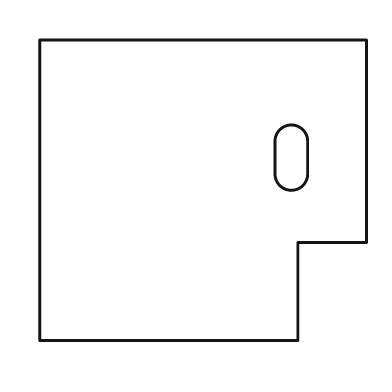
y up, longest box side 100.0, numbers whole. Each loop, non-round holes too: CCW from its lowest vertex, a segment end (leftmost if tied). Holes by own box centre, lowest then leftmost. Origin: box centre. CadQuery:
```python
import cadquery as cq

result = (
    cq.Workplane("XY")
    .moveTo(-50.0, -46.0)
    .lineTo(29.0, -46.0)
    .lineTo(29.0, -16.0)
    .lineTo(50.0, -16.0)
    .lineTo(50.0, 46.0)
    .lineTo(-50.0, 46.0)
    .close()
    .moveTo(22.0, 5.0)
    .threePointArc((27.0, 0.0), (32.0, 5.0))
    .lineTo(32.0, 15.0)
    .threePointArc((27.0, 20.0), (22.0, 15.0))
    .close()
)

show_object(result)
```